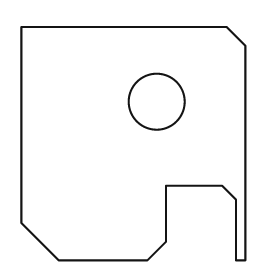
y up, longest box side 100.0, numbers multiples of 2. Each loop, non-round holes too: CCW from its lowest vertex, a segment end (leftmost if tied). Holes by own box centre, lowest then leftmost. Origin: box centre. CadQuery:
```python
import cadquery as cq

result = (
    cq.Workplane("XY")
    .moveTo(-32.0, -50.0)
    .lineTo(6.0, -50.0)
    .lineTo(14.0, -42.0)
    .lineTo(14.0, -18.0)
    .lineTo(38.0, -18.0)
    .lineTo(44.0, -24.0)
    .lineTo(44.0, -50.0)
    .lineTo(48.0, -50.0)
    .lineTo(48.0, 42.0)
    .lineTo(40.0, 50.0)
    .lineTo(-48.0, 50.0)
    .lineTo(-48.0, -34.0)
    .close()
    .moveTo(10.0, 18.0)
    .circle(12.0)
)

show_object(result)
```